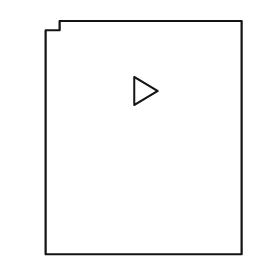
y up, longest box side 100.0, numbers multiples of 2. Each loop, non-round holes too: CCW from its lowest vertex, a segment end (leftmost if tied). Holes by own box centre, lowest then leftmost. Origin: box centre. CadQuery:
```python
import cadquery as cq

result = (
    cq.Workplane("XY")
    .moveTo(-42.0, -50.0)
    .lineTo(42.0, -50.0)
    .lineTo(42.0, 50.0)
    .lineTo(-36.0, 50.0)
    .lineTo(-36.0, 46.0)
    .lineTo(-42.0, 46.0)
    .close()
    .moveTo(-4.0, 14.0)
    .lineTo(6.0, 20.0)
    .lineTo(-4.0, 26.0)
    .close()
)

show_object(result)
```